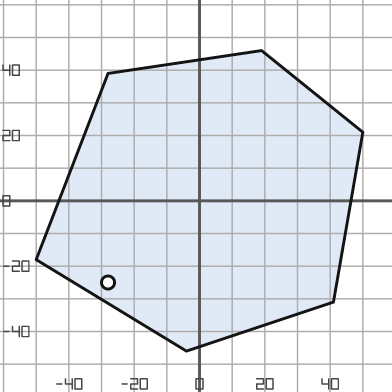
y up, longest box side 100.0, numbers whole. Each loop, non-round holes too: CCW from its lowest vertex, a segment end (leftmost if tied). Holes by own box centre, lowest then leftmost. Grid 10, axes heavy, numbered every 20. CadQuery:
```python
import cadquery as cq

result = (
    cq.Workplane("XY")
    .moveTo(-4.0, -46.0)
    .lineTo(41.0, -31.0)
    .lineTo(50.0, 21.0)
    .lineTo(19.0, 46.0)
    .lineTo(-28.0, 39.0)
    .lineTo(-50.0, -18.0)
    .close()
    .moveTo(-28.0, -25.0)
    .circle(2.0)
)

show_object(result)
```